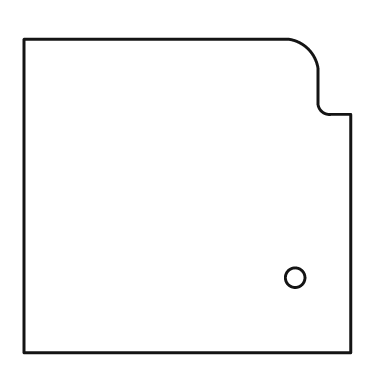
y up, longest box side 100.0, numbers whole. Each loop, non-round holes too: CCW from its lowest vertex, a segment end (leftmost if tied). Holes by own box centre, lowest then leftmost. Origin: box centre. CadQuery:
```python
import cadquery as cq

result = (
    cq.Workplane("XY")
    .moveTo(-50.0, -48.0)
    .lineTo(50.0, -48.0)
    .lineTo(50.0, 25.0)
    .lineTo(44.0, 25.0)
    .threePointArc((41.0, 26.0), (40.0, 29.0))
    .lineTo(40.0, 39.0)
    .threePointArc((37.0, 45.0), (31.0, 48.0))
    .lineTo(-50.0, 48.0)
    .close()
    .moveTo(33.0, -25.0)
    .circle(3.0)
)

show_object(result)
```